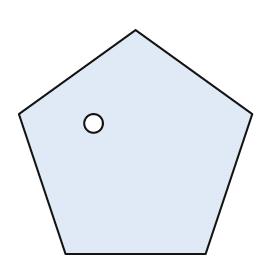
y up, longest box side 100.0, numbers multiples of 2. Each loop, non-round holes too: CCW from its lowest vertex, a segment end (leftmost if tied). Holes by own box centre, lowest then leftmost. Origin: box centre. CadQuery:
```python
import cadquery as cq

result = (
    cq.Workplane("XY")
    .moveTo(-30.0, -48.0)
    .lineTo(30.0, -48.0)
    .lineTo(50.0, 12.0)
    .lineTo(0.0, 48.0)
    .lineTo(-50.0, 12.0)
    .close()
    .moveTo(-18.0, 8.0)
    .circle(4.0)
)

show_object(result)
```